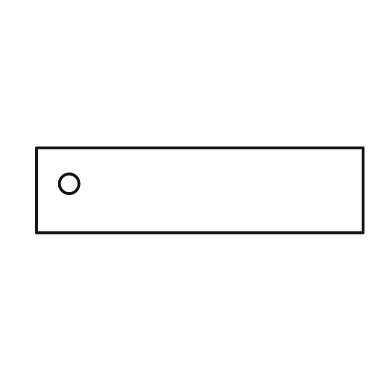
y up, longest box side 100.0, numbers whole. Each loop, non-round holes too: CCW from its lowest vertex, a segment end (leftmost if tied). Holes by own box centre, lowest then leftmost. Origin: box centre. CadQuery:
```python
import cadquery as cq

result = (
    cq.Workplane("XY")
    .moveTo(-50.0, -13.0)
    .lineTo(50.0, -13.0)
    .lineTo(50.0, 13.0)
    .lineTo(-50.0, 13.0)
    .close()
    .moveTo(-40.0, 2.0)
    .circle(3.0)
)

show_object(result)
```